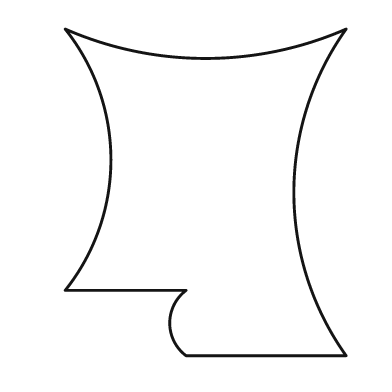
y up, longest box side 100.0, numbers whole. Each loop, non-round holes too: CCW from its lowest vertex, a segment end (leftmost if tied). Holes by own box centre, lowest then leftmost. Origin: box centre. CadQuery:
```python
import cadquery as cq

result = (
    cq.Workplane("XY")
    .moveTo(-6.0, -50.0)
    .lineTo(43.0, -50.0)
    .threePointArc((27.0, 0.0), (43.0, 50.0))
    .threePointArc((0.0, 41.0), (-43.0, 50.0))
    .threePointArc((-29.0, 10.0), (-43.0, -30.0))
    .lineTo(-6.0, -30.0)
    .threePointArc((-11.0, -40.0), (-6.0, -50.0))
    .close()
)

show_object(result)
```